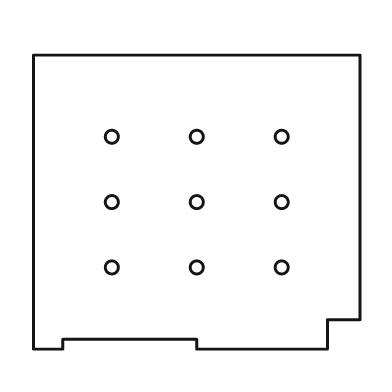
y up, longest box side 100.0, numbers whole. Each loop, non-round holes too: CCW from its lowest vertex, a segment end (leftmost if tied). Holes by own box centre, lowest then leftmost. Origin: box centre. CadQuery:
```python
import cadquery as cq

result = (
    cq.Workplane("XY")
    .moveTo(-50.0, -45.0)
    .lineTo(-41.0, -45.0)
    .lineTo(-41.0, -42.0)
    .lineTo(0.0, -42.0)
    .lineTo(0.0, -45.0)
    .lineTo(40.0, -45.0)
    .lineTo(40.0, -36.0)
    .lineTo(50.0, -36.0)
    .lineTo(50.0, 45.0)
    .lineTo(-50.0, 45.0)
    .close()
    .moveTo(-26.0, -20.0)
    .circle(2.0)
    .moveTo(0.0, -20.0)
    .circle(2.0)
    .moveTo(26.0, -20.0)
    .circle(2.0)
    .moveTo(-26.0, 0.0)
    .circle(2.0)
    .moveTo(0.0, 0.0)
    .circle(2.0)
    .moveTo(26.0, 0.0)
    .circle(2.0)
    .moveTo(-26.0, 20.0)
    .circle(2.0)
    .moveTo(0.0, 20.0)
    .circle(2.0)
    .moveTo(26.0, 20.0)
    .circle(2.0)
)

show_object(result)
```